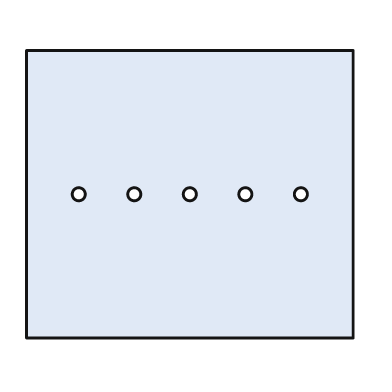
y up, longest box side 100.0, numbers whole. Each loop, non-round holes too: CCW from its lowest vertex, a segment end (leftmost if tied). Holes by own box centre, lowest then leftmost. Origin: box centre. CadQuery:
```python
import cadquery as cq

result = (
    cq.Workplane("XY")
    .moveTo(-50.0, -44.0)
    .lineTo(50.0, -44.0)
    .lineTo(50.0, 44.0)
    .lineTo(-50.0, 44.0)
    .close()
    .moveTo(-34.0, 0.0)
    .circle(2.0)
    .moveTo(-17.0, 0.0)
    .circle(2.0)
    .moveTo(0.0, 0.0)
    .circle(2.0)
    .moveTo(17.0, 0.0)
    .circle(2.0)
    .moveTo(34.0, 0.0)
    .circle(2.0)
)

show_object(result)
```